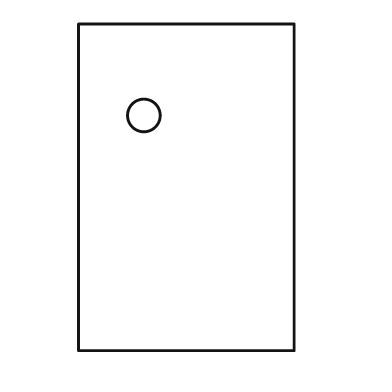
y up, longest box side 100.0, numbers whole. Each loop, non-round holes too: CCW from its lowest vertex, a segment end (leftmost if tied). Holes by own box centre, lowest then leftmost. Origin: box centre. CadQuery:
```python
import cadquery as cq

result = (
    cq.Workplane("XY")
    .moveTo(-33.0, -50.0)
    .lineTo(33.0, -50.0)
    .lineTo(33.0, 50.0)
    .lineTo(-33.0, 50.0)
    .close()
    .moveTo(-13.0, 22.0)
    .circle(5.0)
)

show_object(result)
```